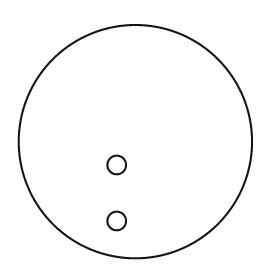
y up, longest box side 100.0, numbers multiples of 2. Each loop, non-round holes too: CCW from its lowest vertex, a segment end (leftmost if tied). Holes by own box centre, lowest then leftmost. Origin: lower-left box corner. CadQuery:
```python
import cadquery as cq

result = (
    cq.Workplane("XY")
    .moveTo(50.0, 50.0)
    .circle(50.0)
    .moveTo(42.0, 16.0)
    .circle(4.0)
    .moveTo(42.0, 40.0)
    .circle(4.0)
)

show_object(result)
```